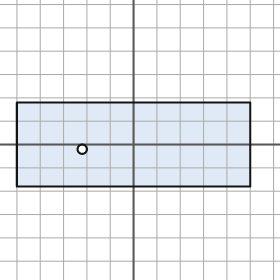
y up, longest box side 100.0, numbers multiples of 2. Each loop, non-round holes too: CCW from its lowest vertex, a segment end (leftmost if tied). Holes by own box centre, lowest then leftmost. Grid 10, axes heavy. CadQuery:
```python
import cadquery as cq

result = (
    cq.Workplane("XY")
    .moveTo(-50.0, -18.0)
    .lineTo(50.0, -18.0)
    .lineTo(50.0, 18.0)
    .lineTo(-50.0, 18.0)
    .close()
    .moveTo(-22.0, -2.0)
    .circle(2.0)
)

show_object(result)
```